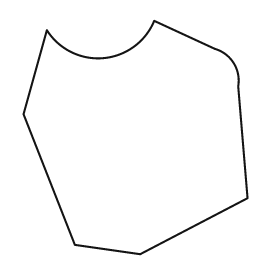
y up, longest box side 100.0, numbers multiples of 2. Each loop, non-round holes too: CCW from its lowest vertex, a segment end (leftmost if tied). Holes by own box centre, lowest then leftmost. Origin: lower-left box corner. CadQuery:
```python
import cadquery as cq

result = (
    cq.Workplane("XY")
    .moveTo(50.0, 0.0)
    .lineTo(96.0, 24.0)
    .lineTo(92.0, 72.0)
    .threePointArc((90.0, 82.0), (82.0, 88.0))
    .lineTo(56.0, 100.0)
    .threePointArc((34.0, 84.0), (10.0, 96.0))
    .lineTo(0.0, 60.0)
    .lineTo(22.0, 4.0)
    .close()
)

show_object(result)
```